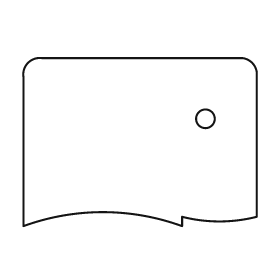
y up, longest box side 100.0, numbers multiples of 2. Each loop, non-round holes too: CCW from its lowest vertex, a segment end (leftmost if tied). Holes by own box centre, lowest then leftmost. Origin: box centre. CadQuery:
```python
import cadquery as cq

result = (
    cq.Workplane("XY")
    .moveTo(-50.0, -36.0)
    .threePointArc((-16.0, -30.0), (18.0, -36.0))
    .lineTo(18.0, -32.0)
    .threePointArc((34.0, -34.0), (50.0, -32.0))
    .lineTo(50.0, 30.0)
    .threePointArc((48.0, 34.0), (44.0, 36.0))
    .lineTo(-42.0, 36.0)
    .threePointArc((-48.0, 34.0), (-50.0, 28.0))
    .close()
    .moveTo(28.0, 10.0)
    .circle(4.0)
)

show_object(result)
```